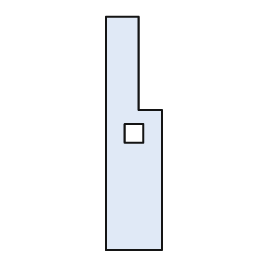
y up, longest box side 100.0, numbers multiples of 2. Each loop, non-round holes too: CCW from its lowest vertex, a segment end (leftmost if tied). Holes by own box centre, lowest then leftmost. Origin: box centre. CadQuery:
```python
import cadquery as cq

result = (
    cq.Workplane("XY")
    .moveTo(-12.0, -50.0)
    .lineTo(12.0, -50.0)
    .lineTo(12.0, 10.0)
    .lineTo(2.0, 10.0)
    .lineTo(2.0, 50.0)
    .lineTo(-12.0, 50.0)
    .close()
    .moveTo(-4.0, -4.0)
    .lineTo(4.0, -4.0)
    .lineTo(4.0, 4.0)
    .lineTo(-4.0, 4.0)
    .close()
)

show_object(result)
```